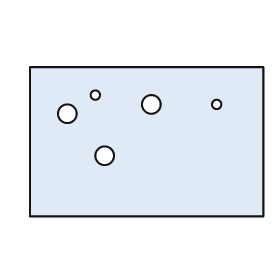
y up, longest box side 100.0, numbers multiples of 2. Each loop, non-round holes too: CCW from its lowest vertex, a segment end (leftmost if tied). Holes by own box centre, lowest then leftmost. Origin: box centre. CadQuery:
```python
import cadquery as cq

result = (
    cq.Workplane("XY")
    .moveTo(-50.0, -32.0)
    .lineTo(50.0, -32.0)
    .lineTo(50.0, 32.0)
    .lineTo(-50.0, 32.0)
    .close()
    .moveTo(-18.0, -6.0)
    .circle(4.0)
    .moveTo(-34.0, 12.0)
    .circle(4.0)
    .moveTo(2.0, 16.0)
    .circle(4.0)
    .moveTo(30.0, 16.0)
    .circle(2.0)
    .moveTo(-22.0, 20.0)
    .circle(2.0)
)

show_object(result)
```